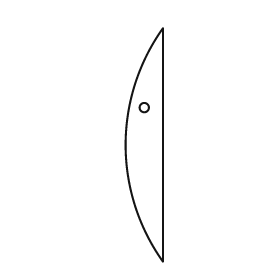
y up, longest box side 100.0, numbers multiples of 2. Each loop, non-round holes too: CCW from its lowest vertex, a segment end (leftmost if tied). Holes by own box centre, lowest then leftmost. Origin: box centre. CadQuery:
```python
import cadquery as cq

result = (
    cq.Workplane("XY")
    .moveTo(8.0, -50.0)
    .lineTo(8.0, 50.0)
    .threePointArc((-8.0, 0.0), (8.0, -50.0))
    .close()
    .moveTo(0.0, 16.0)
    .circle(2.0)
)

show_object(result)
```